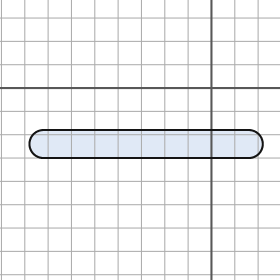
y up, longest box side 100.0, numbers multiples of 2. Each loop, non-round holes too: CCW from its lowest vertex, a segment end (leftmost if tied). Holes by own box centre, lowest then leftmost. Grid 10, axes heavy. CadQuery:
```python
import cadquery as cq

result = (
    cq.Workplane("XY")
    .moveTo(-72.0, -30.0)
    .lineTo(16.0, -30.0)
    .threePointArc((22.0, -24.0), (16.0, -18.0))
    .lineTo(-72.0, -18.0)
    .threePointArc((-78.0, -24.0), (-72.0, -30.0))
    .close()
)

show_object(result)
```